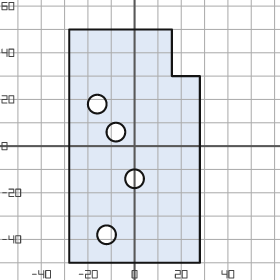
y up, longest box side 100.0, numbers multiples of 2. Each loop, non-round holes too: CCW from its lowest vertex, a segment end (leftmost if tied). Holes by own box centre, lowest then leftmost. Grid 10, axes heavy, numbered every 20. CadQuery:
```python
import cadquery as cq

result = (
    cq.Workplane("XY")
    .moveTo(-28.0, -50.0)
    .lineTo(28.0, -50.0)
    .lineTo(28.0, 30.0)
    .lineTo(16.0, 30.0)
    .lineTo(16.0, 50.0)
    .lineTo(-28.0, 50.0)
    .close()
    .moveTo(-12.0, -38.0)
    .circle(4.0)
    .moveTo(0.0, -14.0)
    .circle(4.0)
    .moveTo(-8.0, 6.0)
    .circle(4.0)
    .moveTo(-16.0, 18.0)
    .circle(4.0)
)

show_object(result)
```